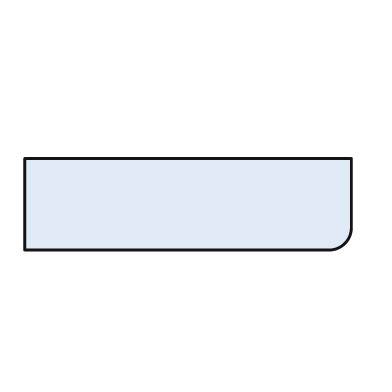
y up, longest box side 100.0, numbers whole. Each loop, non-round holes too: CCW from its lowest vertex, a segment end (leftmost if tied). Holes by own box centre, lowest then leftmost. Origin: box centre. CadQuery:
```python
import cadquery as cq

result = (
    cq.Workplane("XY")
    .moveTo(-50.0, -14.0)
    .lineTo(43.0, -14.0)
    .threePointArc((48.0, -12.0), (50.0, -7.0))
    .lineTo(50.0, 14.0)
    .lineTo(-50.0, 14.0)
    .close()
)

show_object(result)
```